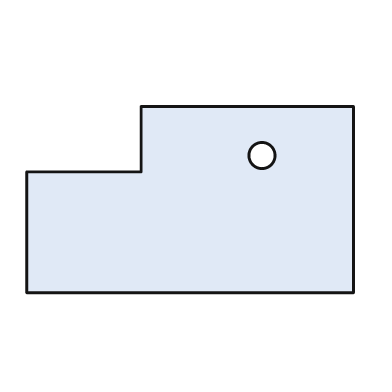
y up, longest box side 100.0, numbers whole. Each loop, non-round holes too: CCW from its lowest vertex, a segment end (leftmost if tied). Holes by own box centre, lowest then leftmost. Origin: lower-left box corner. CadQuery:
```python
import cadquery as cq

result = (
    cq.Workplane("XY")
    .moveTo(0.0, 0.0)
    .lineTo(100.0, 0.0)
    .lineTo(100.0, 57.0)
    .lineTo(35.0, 57.0)
    .lineTo(35.0, 37.0)
    .lineTo(0.0, 37.0)
    .close()
    .moveTo(72.0, 42.0)
    .circle(4.0)
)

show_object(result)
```